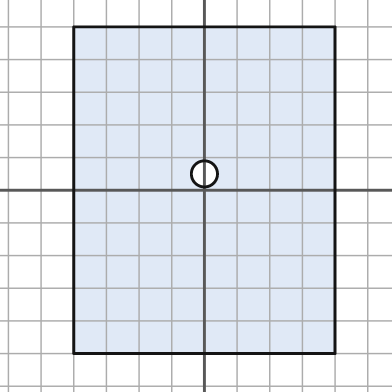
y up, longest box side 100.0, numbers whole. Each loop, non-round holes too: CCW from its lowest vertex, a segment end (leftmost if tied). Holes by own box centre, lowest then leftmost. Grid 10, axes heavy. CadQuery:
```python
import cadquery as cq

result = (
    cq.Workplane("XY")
    .moveTo(-40.0, -50.0)
    .lineTo(40.0, -50.0)
    .lineTo(40.0, 50.0)
    .lineTo(-40.0, 50.0)
    .close()
    .moveTo(0.0, 5.0)
    .circle(4.0)
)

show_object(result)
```